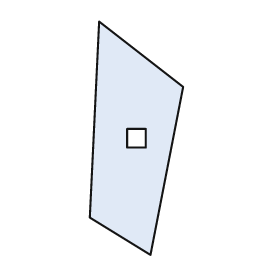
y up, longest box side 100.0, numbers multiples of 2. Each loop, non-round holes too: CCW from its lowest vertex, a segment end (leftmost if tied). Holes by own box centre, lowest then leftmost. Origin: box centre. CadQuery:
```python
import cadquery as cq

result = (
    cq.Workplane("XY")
    .moveTo(6.0, -50.0)
    .lineTo(20.0, 22.0)
    .lineTo(-16.0, 50.0)
    .lineTo(-20.0, -34.0)
    .close()
    .moveTo(-4.0, -4.0)
    .lineTo(4.0, -4.0)
    .lineTo(4.0, 4.0)
    .lineTo(-4.0, 4.0)
    .close()
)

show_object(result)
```